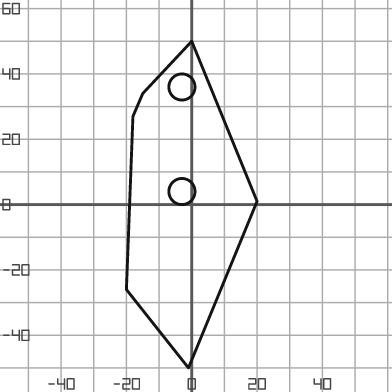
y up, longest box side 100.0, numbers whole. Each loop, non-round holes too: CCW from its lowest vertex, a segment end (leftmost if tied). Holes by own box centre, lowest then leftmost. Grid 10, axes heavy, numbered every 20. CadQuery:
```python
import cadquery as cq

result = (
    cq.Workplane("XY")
    .moveTo(-1.0, -50.0)
    .lineTo(20.0, 1.0)
    .lineTo(0.0, 50.0)
    .lineTo(-15.0, 34.0)
    .lineTo(-18.0, 27.0)
    .lineTo(-20.0, -26.0)
    .close()
    .moveTo(-3.0, 4.0)
    .circle(4.0)
    .moveTo(-3.0, 36.0)
    .circle(4.0)
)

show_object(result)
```